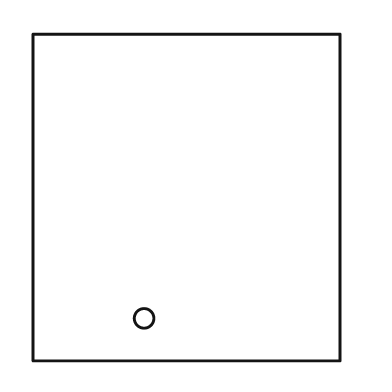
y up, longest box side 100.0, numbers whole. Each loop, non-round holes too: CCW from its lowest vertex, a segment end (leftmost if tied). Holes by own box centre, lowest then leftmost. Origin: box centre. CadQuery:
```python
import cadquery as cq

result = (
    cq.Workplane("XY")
    .moveTo(-47.0, -50.0)
    .lineTo(47.0, -50.0)
    .lineTo(47.0, 50.0)
    .lineTo(-47.0, 50.0)
    .close()
    .moveTo(-13.0, -37.0)
    .circle(3.0)
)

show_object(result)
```